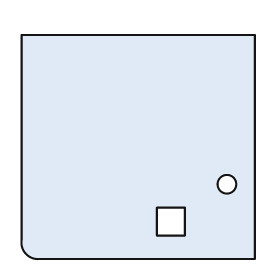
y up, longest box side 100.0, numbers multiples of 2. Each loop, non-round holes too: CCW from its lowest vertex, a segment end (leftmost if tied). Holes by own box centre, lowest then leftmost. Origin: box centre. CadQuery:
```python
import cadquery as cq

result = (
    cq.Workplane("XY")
    .moveTo(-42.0, -48.0)
    .lineTo(50.0, -48.0)
    .lineTo(50.0, 48.0)
    .lineTo(-50.0, 48.0)
    .lineTo(-50.0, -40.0)
    .threePointArc((-48.0, -46.0), (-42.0, -48.0))
    .close()
    .moveTo(8.0, -38.0)
    .lineTo(20.0, -38.0)
    .lineTo(20.0, -26.0)
    .lineTo(8.0, -26.0)
    .close()
    .moveTo(38.0, -16.0)
    .circle(4.0)
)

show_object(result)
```